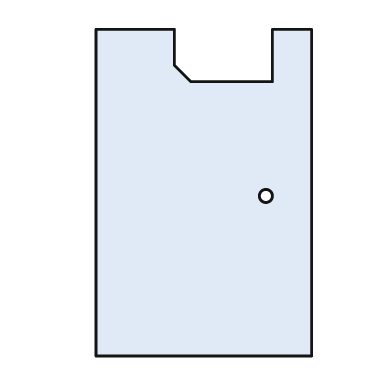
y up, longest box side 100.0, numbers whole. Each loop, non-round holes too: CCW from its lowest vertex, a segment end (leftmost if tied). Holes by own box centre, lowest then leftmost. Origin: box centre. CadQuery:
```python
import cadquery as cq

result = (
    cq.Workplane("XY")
    .moveTo(-33.0, -50.0)
    .lineTo(33.0, -50.0)
    .lineTo(33.0, 50.0)
    .lineTo(21.0, 50.0)
    .lineTo(21.0, 34.0)
    .lineTo(-4.0, 34.0)
    .lineTo(-9.0, 39.0)
    .lineTo(-9.0, 50.0)
    .lineTo(-33.0, 50.0)
    .close()
    .moveTo(19.0, -1.0)
    .circle(2.0)
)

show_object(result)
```